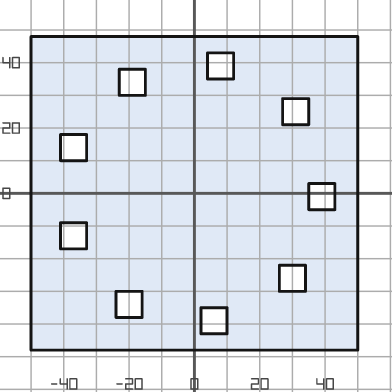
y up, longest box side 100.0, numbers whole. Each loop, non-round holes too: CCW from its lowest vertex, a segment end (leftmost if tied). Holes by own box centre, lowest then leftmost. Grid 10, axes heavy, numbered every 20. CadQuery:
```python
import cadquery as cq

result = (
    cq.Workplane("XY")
    .moveTo(-50.0, -48.0)
    .lineTo(50.0, -48.0)
    .lineTo(50.0, 48.0)
    .lineTo(-50.0, 48.0)
    .close()
    .moveTo(2.0, -43.0)
    .lineTo(10.0, -43.0)
    .lineTo(10.0, -35.0)
    .lineTo(2.0, -35.0)
    .close()
    .moveTo(-24.0, -38.0)
    .lineTo(-16.0, -38.0)
    .lineTo(-16.0, -30.0)
    .lineTo(-24.0, -30.0)
    .close()
    .moveTo(26.0, -30.0)
    .lineTo(34.0, -30.0)
    .lineTo(34.0, -22.0)
    .lineTo(26.0, -22.0)
    .close()
    .moveTo(-41.0, -17.0)
    .lineTo(-33.0, -17.0)
    .lineTo(-33.0, -9.0)
    .lineTo(-41.0, -9.0)
    .close()
    .moveTo(35.0, -5.0)
    .lineTo(43.0, -5.0)
    .lineTo(43.0, 3.0)
    .lineTo(35.0, 3.0)
    .close()
    .moveTo(-41.0, 10.0)
    .lineTo(-33.0, 10.0)
    .lineTo(-33.0, 18.0)
    .lineTo(-41.0, 18.0)
    .close()
    .moveTo(27.0, 21.0)
    .lineTo(35.0, 21.0)
    .lineTo(35.0, 29.0)
    .lineTo(27.0, 29.0)
    .close()
    .moveTo(-23.0, 30.0)
    .lineTo(-15.0, 30.0)
    .lineTo(-15.0, 38.0)
    .lineTo(-23.0, 38.0)
    .close()
    .moveTo(4.0, 35.0)
    .lineTo(12.0, 35.0)
    .lineTo(12.0, 43.0)
    .lineTo(4.0, 43.0)
    .close()
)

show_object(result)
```